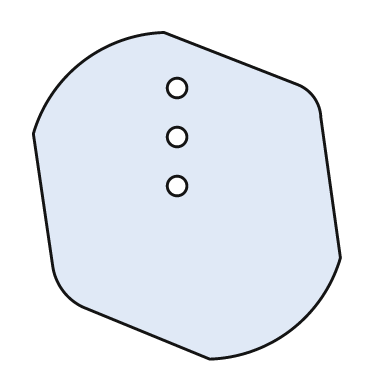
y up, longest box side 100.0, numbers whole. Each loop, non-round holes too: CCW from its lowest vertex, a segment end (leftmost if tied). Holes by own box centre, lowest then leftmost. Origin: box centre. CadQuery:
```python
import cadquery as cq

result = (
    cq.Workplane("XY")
    .moveTo(7.0, -50.0)
    .threePointArc((32.0, -41.0), (47.0, -19.0))
    .lineTo(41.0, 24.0)
    .threePointArc((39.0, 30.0), (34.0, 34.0))
    .lineTo(-7.0, 50.0)
    .threePointArc((-32.0, 41.0), (-47.0, 19.0))
    .lineTo(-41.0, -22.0)
    .threePointArc((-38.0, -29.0), (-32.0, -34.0))
    .close()
    .moveTo(-3.0, 3.0)
    .circle(3.0)
    .moveTo(-3.0, 18.0)
    .circle(3.0)
    .moveTo(-3.0, 33.0)
    .circle(3.0)
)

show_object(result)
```